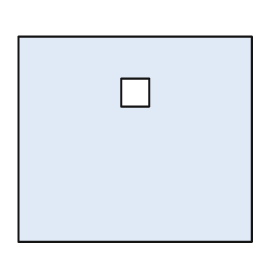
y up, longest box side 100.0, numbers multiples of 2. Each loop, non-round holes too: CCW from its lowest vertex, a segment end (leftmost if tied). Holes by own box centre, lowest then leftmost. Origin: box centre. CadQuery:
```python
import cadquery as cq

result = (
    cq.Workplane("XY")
    .moveTo(-50.0, -44.0)
    .lineTo(50.0, -44.0)
    .lineTo(50.0, 44.0)
    .lineTo(-50.0, 44.0)
    .close()
    .moveTo(-6.0, 14.0)
    .lineTo(6.0, 14.0)
    .lineTo(6.0, 26.0)
    .lineTo(-6.0, 26.0)
    .close()
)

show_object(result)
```